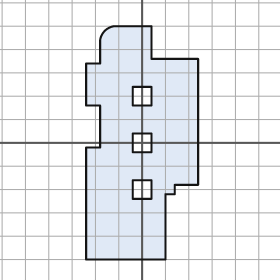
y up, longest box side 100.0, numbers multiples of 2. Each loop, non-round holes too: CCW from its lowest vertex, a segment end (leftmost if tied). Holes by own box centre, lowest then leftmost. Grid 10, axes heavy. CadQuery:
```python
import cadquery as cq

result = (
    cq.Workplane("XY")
    .moveTo(-24.0, -50.0)
    .lineTo(10.0, -50.0)
    .lineTo(10.0, -22.0)
    .lineTo(14.0, -22.0)
    .lineTo(14.0, -18.0)
    .lineTo(24.0, -18.0)
    .lineTo(24.0, 36.0)
    .lineTo(4.0, 36.0)
    .lineTo(4.0, 50.0)
    .lineTo(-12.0, 50.0)
    .threePointArc((-16.0, 48.0), (-18.0, 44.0))
    .lineTo(-18.0, 34.0)
    .lineTo(-24.0, 34.0)
    .lineTo(-24.0, 16.0)
    .lineTo(-18.0, 16.0)
    .lineTo(-18.0, -2.0)
    .lineTo(-24.0, -2.0)
    .close()
    .moveTo(-4.0, -24.0)
    .lineTo(4.0, -24.0)
    .lineTo(4.0, -16.0)
    .lineTo(-4.0, -16.0)
    .close()
    .moveTo(-4.0, -4.0)
    .lineTo(4.0, -4.0)
    .lineTo(4.0, 4.0)
    .lineTo(-4.0, 4.0)
    .close()
    .moveTo(-4.0, 16.0)
    .lineTo(4.0, 16.0)
    .lineTo(4.0, 24.0)
    .lineTo(-4.0, 24.0)
    .close()
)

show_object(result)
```